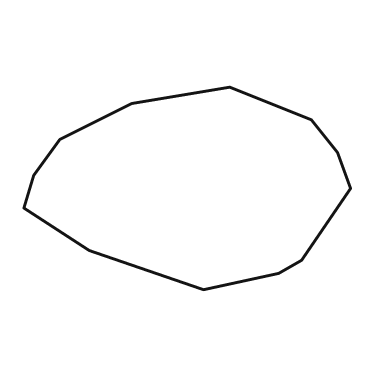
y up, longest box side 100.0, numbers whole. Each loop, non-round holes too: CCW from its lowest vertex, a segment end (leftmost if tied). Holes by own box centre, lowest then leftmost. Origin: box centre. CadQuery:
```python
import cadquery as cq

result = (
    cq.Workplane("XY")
    .moveTo(5.0, -31.0)
    .lineTo(28.0, -26.0)
    .lineTo(35.0, -22.0)
    .lineTo(50.0, 0.0)
    .lineTo(46.0, 11.0)
    .lineTo(38.0, 21.0)
    .lineTo(13.0, 31.0)
    .lineTo(-17.0, 26.0)
    .lineTo(-39.0, 15.0)
    .lineTo(-47.0, 4.0)
    .lineTo(-50.0, -6.0)
    .lineTo(-30.0, -19.0)
    .close()
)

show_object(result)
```